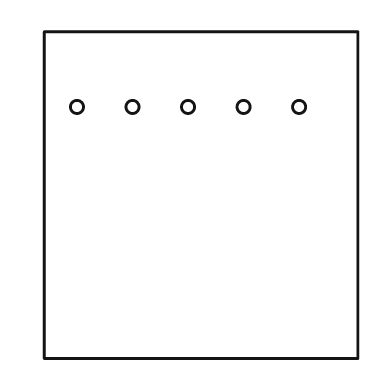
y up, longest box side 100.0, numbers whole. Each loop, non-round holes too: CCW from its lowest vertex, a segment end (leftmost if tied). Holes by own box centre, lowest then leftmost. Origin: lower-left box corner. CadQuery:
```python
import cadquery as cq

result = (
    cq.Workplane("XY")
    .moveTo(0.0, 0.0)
    .lineTo(96.0, 0.0)
    .lineTo(96.0, 100.0)
    .lineTo(0.0, 100.0)
    .close()
    .moveTo(10.0, 77.0)
    .circle(2.0)
    .moveTo(27.0, 77.0)
    .circle(2.0)
    .moveTo(44.0, 77.0)
    .circle(2.0)
    .moveTo(61.0, 77.0)
    .circle(2.0)
    .moveTo(78.0, 77.0)
    .circle(2.0)
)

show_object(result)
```